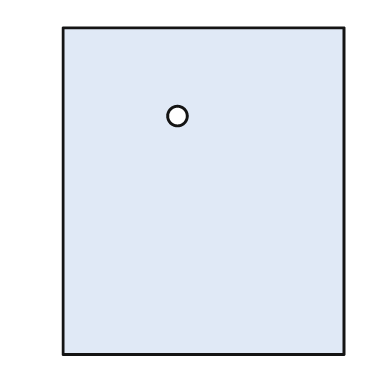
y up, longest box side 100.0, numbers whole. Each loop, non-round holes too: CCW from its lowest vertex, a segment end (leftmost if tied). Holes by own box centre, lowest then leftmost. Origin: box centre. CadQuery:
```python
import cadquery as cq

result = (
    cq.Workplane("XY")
    .moveTo(-43.0, -50.0)
    .lineTo(43.0, -50.0)
    .lineTo(43.0, 50.0)
    .lineTo(-43.0, 50.0)
    .close()
    .moveTo(-8.0, 23.0)
    .circle(3.0)
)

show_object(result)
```